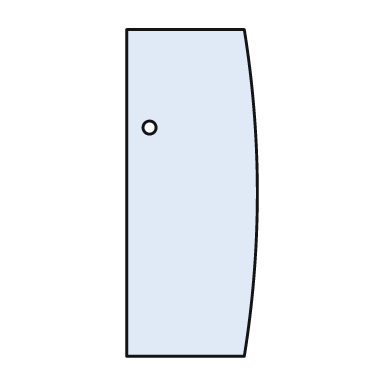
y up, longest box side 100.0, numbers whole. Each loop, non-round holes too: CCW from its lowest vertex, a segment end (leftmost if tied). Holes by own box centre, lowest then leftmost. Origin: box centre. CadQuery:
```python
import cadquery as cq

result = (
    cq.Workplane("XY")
    .moveTo(-20.0, -50.0)
    .lineTo(16.0, -50.0)
    .threePointArc((20.0, 0.0), (16.0, 50.0))
    .lineTo(-20.0, 50.0)
    .close()
    .moveTo(-13.0, 20.0)
    .circle(2.0)
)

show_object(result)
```